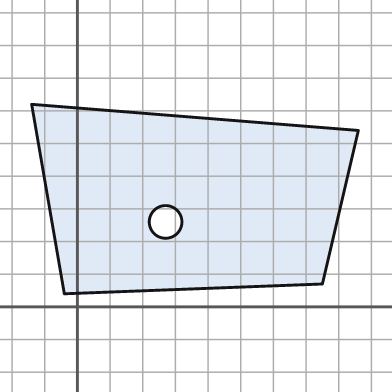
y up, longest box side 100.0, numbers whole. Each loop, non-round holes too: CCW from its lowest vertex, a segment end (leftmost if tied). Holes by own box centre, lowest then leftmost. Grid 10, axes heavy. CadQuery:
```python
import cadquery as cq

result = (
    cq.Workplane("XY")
    .moveTo(-4.0, 4.0)
    .lineTo(75.0, 7.0)
    .lineTo(86.0, 54.0)
    .lineTo(-14.0, 62.0)
    .close()
    .moveTo(27.0, 26.0)
    .circle(5.0)
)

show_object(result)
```